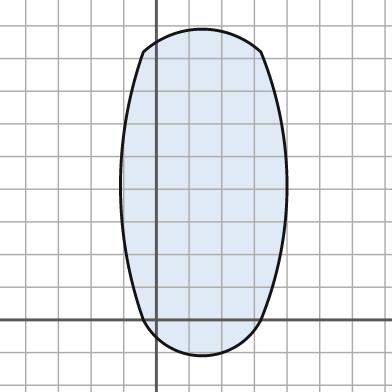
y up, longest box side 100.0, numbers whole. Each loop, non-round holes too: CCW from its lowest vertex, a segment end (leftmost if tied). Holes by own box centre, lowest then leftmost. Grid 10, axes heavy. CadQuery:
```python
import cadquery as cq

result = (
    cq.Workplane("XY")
    .moveTo(-4.0, 0.0)
    .threePointArc((14.0, -11.0), (32.0, 0.0))
    .threePointArc((40.0, 41.0), (32.0, 82.0))
    .threePointArc((14.0, 89.0), (-4.0, 82.0))
    .threePointArc((-11.0, 41.0), (-4.0, 0.0))
    .close()
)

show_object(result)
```